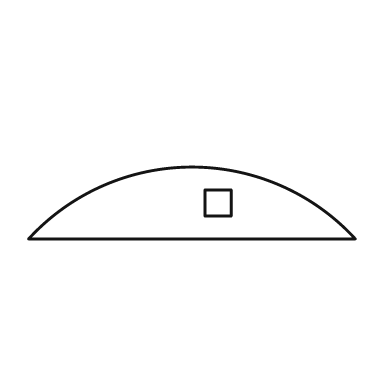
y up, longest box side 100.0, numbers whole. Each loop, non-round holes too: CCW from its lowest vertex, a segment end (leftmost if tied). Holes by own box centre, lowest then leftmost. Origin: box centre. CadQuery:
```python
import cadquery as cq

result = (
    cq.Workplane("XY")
    .moveTo(-50.0, -11.0)
    .lineTo(50.0, -11.0)
    .threePointArc((0.0, 11.0), (-50.0, -11.0))
    .close()
    .moveTo(4.0, -4.0)
    .lineTo(12.0, -4.0)
    .lineTo(12.0, 4.0)
    .lineTo(4.0, 4.0)
    .close()
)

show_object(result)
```